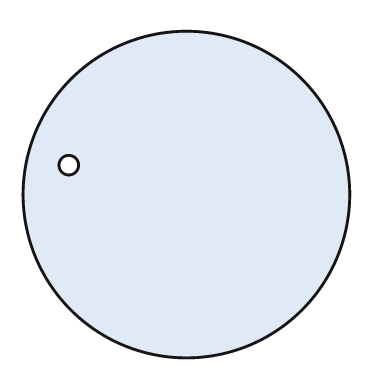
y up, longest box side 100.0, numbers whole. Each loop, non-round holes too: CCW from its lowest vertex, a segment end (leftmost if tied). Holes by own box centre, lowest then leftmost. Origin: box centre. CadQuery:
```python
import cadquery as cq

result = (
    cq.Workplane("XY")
    .moveTo(0.0, 0.0)
    .circle(50.0)
    .moveTo(-36.0, 9.0)
    .circle(3.0)
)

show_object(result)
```